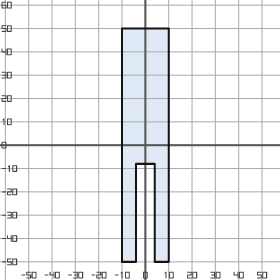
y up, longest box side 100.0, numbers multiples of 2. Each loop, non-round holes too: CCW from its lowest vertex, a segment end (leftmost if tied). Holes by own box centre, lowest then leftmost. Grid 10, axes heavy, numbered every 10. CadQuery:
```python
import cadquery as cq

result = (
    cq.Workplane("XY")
    .moveTo(-10.0, -50.0)
    .lineTo(-4.0, -50.0)
    .lineTo(-4.0, -8.0)
    .lineTo(4.0, -8.0)
    .lineTo(4.0, -50.0)
    .lineTo(10.0, -50.0)
    .lineTo(10.0, 50.0)
    .lineTo(-10.0, 50.0)
    .close()
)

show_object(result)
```